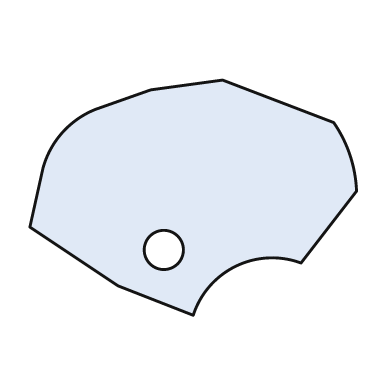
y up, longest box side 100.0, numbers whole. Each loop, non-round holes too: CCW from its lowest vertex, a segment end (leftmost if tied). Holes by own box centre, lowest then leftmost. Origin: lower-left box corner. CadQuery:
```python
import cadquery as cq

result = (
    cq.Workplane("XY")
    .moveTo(50.0, 0.0)
    .threePointArc((63.0, 15.0), (83.0, 16.0))
    .lineTo(100.0, 38.0)
    .threePointArc((98.0, 49.0), (93.0, 59.0))
    .lineTo(59.0, 72.0)
    .lineTo(37.0, 69.0)
    .lineTo(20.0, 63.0)
    .threePointArc((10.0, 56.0), (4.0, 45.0))
    .lineTo(0.0, 27.0)
    .lineTo(27.0, 9.0)
    .close()
    .moveTo(41.0, 20.0)
    .circle(6.0)
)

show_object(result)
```